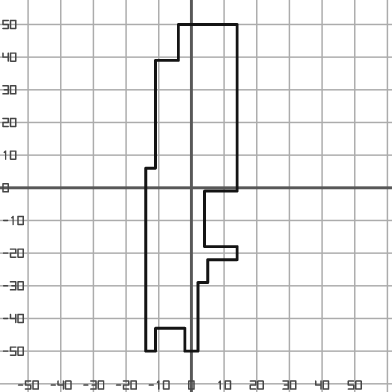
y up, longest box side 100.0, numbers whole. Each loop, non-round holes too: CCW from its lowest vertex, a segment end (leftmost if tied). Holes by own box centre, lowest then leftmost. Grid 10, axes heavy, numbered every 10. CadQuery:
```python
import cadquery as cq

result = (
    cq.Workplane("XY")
    .moveTo(-14.0, -50.0)
    .lineTo(-11.0, -50.0)
    .lineTo(-11.0, -43.0)
    .lineTo(-2.0, -43.0)
    .lineTo(-2.0, -50.0)
    .lineTo(2.0, -50.0)
    .lineTo(2.0, -29.0)
    .lineTo(5.0, -29.0)
    .lineTo(5.0, -22.0)
    .lineTo(14.0, -22.0)
    .lineTo(14.0, -18.0)
    .lineTo(4.0, -18.0)
    .lineTo(4.0, -1.0)
    .lineTo(14.0, -1.0)
    .lineTo(14.0, 50.0)
    .lineTo(-4.0, 50.0)
    .lineTo(-4.0, 39.0)
    .lineTo(-11.0, 39.0)
    .lineTo(-11.0, 6.0)
    .lineTo(-14.0, 6.0)
    .close()
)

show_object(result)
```